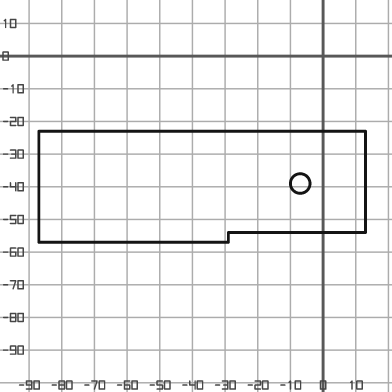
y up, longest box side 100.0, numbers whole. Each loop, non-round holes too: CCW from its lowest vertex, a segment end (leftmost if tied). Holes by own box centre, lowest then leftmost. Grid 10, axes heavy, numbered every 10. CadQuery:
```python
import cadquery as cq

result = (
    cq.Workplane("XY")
    .moveTo(-87.0, -57.0)
    .lineTo(-29.0, -57.0)
    .lineTo(-29.0, -54.0)
    .lineTo(13.0, -54.0)
    .lineTo(13.0, -23.0)
    .lineTo(-87.0, -23.0)
    .close()
    .moveTo(-7.0, -39.0)
    .circle(3.0)
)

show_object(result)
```